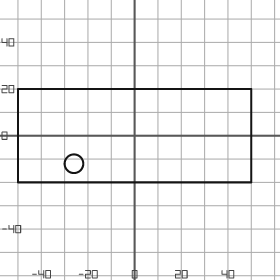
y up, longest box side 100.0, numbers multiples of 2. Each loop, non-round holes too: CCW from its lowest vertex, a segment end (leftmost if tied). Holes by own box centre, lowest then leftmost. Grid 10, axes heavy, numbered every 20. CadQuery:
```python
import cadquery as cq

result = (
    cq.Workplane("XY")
    .moveTo(-50.0, -20.0)
    .lineTo(50.0, -20.0)
    .lineTo(50.0, 20.0)
    .lineTo(-50.0, 20.0)
    .close()
    .moveTo(-26.0, -12.0)
    .circle(4.0)
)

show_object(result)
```